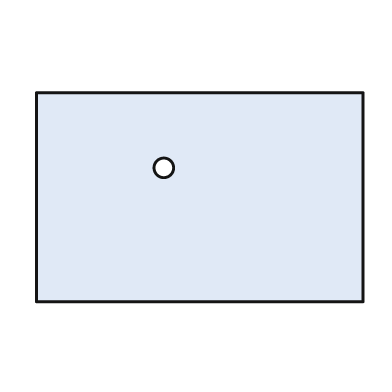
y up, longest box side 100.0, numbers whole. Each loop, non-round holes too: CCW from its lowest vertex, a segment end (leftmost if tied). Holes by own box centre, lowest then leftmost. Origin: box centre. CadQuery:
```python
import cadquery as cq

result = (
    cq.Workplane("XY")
    .moveTo(-50.0, -32.0)
    .lineTo(50.0, -32.0)
    .lineTo(50.0, 32.0)
    .lineTo(-50.0, 32.0)
    .close()
    .moveTo(-11.0, 9.0)
    .circle(3.0)
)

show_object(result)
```